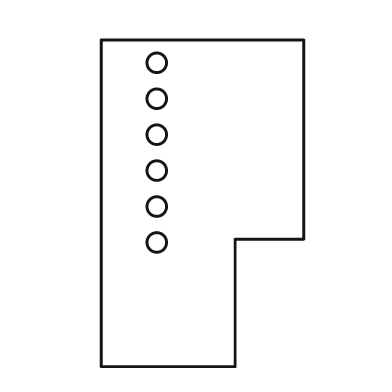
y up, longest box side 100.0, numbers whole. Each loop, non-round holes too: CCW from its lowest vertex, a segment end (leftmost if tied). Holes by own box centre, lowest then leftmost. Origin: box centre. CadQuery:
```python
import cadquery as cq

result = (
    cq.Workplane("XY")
    .moveTo(-31.0, -50.0)
    .lineTo(10.0, -50.0)
    .lineTo(10.0, -11.0)
    .lineTo(31.0, -11.0)
    .lineTo(31.0, 50.0)
    .lineTo(-31.0, 50.0)
    .close()
    .moveTo(-14.0, -12.0)
    .circle(3.0)
    .moveTo(-14.0, -1.0)
    .circle(3.0)
    .moveTo(-14.0, 10.0)
    .circle(3.0)
    .moveTo(-14.0, 21.0)
    .circle(3.0)
    .moveTo(-14.0, 32.0)
    .circle(3.0)
    .moveTo(-14.0, 43.0)
    .circle(3.0)
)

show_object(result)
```